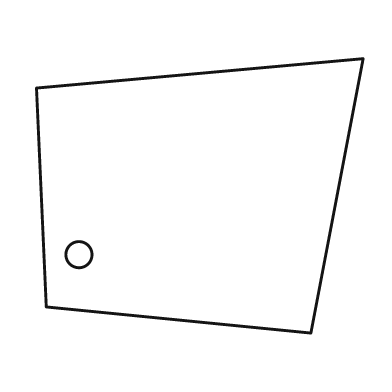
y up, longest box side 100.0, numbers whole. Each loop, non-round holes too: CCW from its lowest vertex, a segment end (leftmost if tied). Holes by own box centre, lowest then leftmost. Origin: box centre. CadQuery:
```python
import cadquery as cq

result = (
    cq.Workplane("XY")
    .moveTo(34.0, -42.0)
    .lineTo(50.0, 42.0)
    .lineTo(-50.0, 33.0)
    .lineTo(-47.0, -34.0)
    .close()
    .moveTo(-37.0, -18.0)
    .circle(4.0)
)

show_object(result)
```